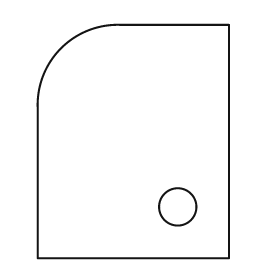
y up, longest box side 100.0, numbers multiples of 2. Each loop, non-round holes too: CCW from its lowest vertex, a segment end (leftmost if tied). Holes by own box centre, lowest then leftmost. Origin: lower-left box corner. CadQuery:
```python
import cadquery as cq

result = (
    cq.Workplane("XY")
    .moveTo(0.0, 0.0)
    .lineTo(82.0, 0.0)
    .lineTo(82.0, 100.0)
    .lineTo(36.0, 100.0)
    .threePointArc((10.0, 90.0), (0.0, 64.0))
    .close()
    .moveTo(60.0, 22.0)
    .circle(8.0)
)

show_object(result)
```